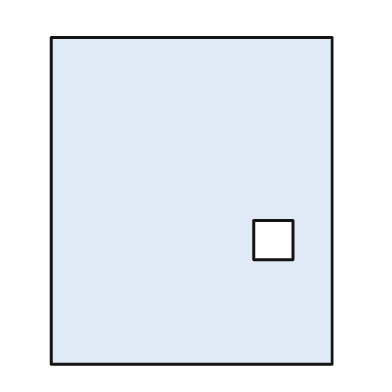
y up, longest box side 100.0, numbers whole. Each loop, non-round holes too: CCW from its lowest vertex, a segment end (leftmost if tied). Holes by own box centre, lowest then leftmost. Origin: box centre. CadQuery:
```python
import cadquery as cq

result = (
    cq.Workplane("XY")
    .moveTo(-43.0, -50.0)
    .lineTo(43.0, -50.0)
    .lineTo(43.0, 50.0)
    .lineTo(-43.0, 50.0)
    .close()
    .moveTo(19.0, -18.0)
    .lineTo(31.0, -18.0)
    .lineTo(31.0, -6.0)
    .lineTo(19.0, -6.0)
    .close()
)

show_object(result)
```